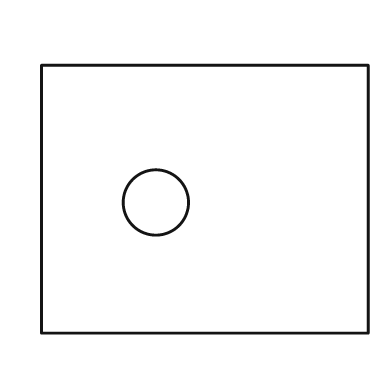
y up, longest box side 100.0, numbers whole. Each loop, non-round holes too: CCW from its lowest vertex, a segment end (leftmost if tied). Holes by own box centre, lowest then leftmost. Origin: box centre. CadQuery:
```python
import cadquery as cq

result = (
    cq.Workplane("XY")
    .moveTo(-50.0, -41.0)
    .lineTo(50.0, -41.0)
    .lineTo(50.0, 41.0)
    .lineTo(-50.0, 41.0)
    .close()
    .moveTo(-15.0, -1.0)
    .circle(10.0)
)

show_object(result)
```